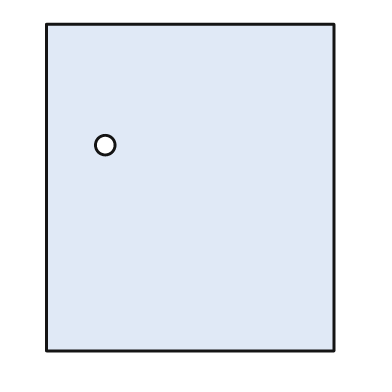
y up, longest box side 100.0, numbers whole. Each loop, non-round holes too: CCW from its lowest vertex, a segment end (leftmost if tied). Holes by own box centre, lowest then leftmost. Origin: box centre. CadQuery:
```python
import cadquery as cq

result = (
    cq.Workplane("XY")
    .moveTo(-44.0, -50.0)
    .lineTo(44.0, -50.0)
    .lineTo(44.0, 50.0)
    .lineTo(-44.0, 50.0)
    .close()
    .moveTo(-26.0, 13.0)
    .circle(3.0)
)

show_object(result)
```